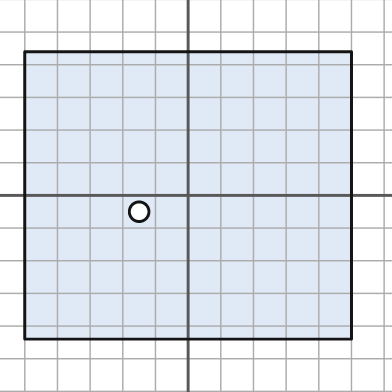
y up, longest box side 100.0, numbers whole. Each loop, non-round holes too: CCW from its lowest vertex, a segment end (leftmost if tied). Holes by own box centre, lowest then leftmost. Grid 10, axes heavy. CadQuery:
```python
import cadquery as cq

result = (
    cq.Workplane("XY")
    .moveTo(-50.0, -44.0)
    .lineTo(50.0, -44.0)
    .lineTo(50.0, 44.0)
    .lineTo(-50.0, 44.0)
    .close()
    .moveTo(-15.0, -5.0)
    .circle(3.0)
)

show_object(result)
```